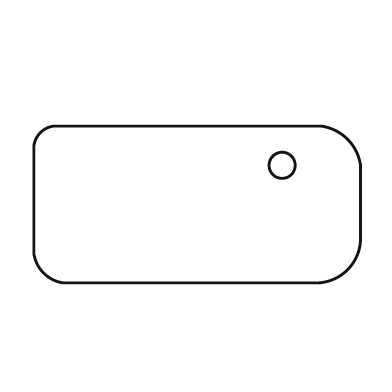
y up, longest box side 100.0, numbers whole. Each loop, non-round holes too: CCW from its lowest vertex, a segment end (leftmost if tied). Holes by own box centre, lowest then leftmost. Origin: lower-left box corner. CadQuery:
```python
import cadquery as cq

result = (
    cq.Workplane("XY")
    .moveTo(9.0, 0.0)
    .lineTo(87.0, 0.0)
    .threePointArc((96.0, 4.0), (100.0, 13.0))
    .lineTo(100.0, 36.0)
    .threePointArc((96.0, 44.0), (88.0, 48.0))
    .lineTo(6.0, 48.0)
    .threePointArc((2.0, 46.0), (0.0, 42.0))
    .lineTo(0.0, 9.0)
    .threePointArc((3.0, 3.0), (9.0, 0.0))
    .close()
    .moveTo(76.0, 36.0)
    .circle(4.0)
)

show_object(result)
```